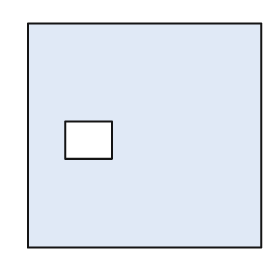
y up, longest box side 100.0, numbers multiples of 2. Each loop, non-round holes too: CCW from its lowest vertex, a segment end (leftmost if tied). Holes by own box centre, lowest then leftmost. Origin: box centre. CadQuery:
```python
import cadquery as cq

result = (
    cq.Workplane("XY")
    .moveTo(-50.0, -48.0)
    .lineTo(50.0, -48.0)
    .lineTo(50.0, 48.0)
    .lineTo(-50.0, 48.0)
    .close()
    .moveTo(-34.0, -10.0)
    .lineTo(-14.0, -10.0)
    .lineTo(-14.0, 6.0)
    .lineTo(-34.0, 6.0)
    .close()
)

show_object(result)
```